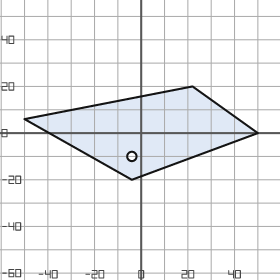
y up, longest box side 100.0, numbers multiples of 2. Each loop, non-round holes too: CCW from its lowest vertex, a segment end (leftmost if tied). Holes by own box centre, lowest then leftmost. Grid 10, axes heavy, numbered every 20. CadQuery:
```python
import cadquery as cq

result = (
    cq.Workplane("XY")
    .moveTo(-4.0, -20.0)
    .lineTo(50.0, 0.0)
    .lineTo(22.0, 20.0)
    .lineTo(-50.0, 6.0)
    .close()
    .moveTo(-4.0, -10.0)
    .circle(2.0)
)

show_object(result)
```